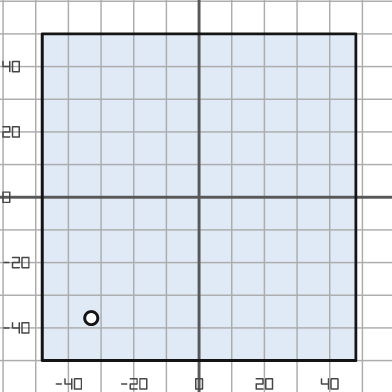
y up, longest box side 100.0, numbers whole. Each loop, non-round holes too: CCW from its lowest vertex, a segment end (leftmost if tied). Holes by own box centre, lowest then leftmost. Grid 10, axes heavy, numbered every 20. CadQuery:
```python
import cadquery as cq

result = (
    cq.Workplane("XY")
    .moveTo(-48.0, -50.0)
    .lineTo(48.0, -50.0)
    .lineTo(48.0, 50.0)
    .lineTo(-48.0, 50.0)
    .close()
    .moveTo(-33.0, -37.0)
    .circle(2.0)
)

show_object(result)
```